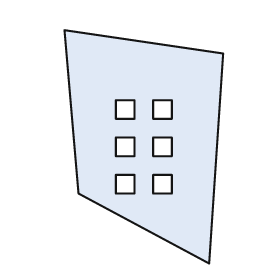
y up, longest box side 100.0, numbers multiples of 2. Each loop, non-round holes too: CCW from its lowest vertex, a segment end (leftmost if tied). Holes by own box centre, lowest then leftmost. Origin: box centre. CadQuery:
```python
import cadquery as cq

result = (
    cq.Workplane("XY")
    .moveTo(28.0, -50.0)
    .lineTo(34.0, 40.0)
    .lineTo(-34.0, 50.0)
    .lineTo(-28.0, -20.0)
    .close()
    .moveTo(-12.0, -20.0)
    .lineTo(-4.0, -20.0)
    .lineTo(-4.0, -12.0)
    .lineTo(-12.0, -12.0)
    .close()
    .moveTo(4.0, -20.0)
    .lineTo(12.0, -20.0)
    .lineTo(12.0, -12.0)
    .lineTo(4.0, -12.0)
    .close()
    .moveTo(-12.0, -4.0)
    .lineTo(-4.0, -4.0)
    .lineTo(-4.0, 4.0)
    .lineTo(-12.0, 4.0)
    .close()
    .moveTo(4.0, -4.0)
    .lineTo(12.0, -4.0)
    .lineTo(12.0, 4.0)
    .lineTo(4.0, 4.0)
    .close()
    .moveTo(-12.0, 12.0)
    .lineTo(-4.0, 12.0)
    .lineTo(-4.0, 20.0)
    .lineTo(-12.0, 20.0)
    .close()
    .moveTo(4.0, 12.0)
    .lineTo(12.0, 12.0)
    .lineTo(12.0, 20.0)
    .lineTo(4.0, 20.0)
    .close()
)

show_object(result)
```